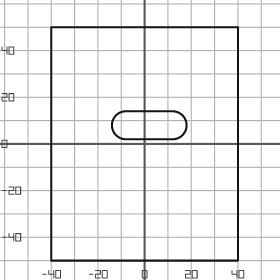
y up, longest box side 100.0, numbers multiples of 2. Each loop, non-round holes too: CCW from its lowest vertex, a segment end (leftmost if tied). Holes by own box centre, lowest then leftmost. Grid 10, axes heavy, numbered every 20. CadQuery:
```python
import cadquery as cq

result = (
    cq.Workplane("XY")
    .moveTo(-40.0, -50.0)
    .lineTo(40.0, -50.0)
    .lineTo(40.0, 50.0)
    .lineTo(-40.0, 50.0)
    .close()
    .moveTo(-8.0, 2.0)
    .lineTo(12.0, 2.0)
    .threePointArc((18.0, 8.0), (12.0, 14.0))
    .lineTo(-8.0, 14.0)
    .threePointArc((-14.0, 8.0), (-8.0, 2.0))
    .close()
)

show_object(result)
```